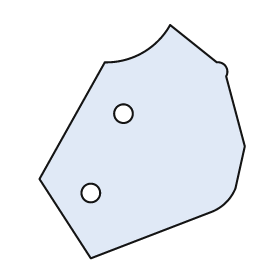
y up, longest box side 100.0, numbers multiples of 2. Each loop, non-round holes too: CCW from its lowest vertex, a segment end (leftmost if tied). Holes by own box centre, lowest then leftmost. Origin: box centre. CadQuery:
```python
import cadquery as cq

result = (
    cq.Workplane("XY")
    .moveTo(-22.0, -50.0)
    .lineTo(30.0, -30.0)
    .threePointArc((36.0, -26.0), (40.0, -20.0))
    .lineTo(44.0, -2.0)
    .lineTo(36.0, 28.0)
    .threePointArc((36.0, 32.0), (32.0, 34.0))
    .lineTo(12.0, 50.0)
    .threePointArc((0.0, 38.0), (-16.0, 34.0))
    .lineTo(-44.0, -16.0)
    .close()
    .moveTo(-22.0, -22.0)
    .circle(4.0)
    .moveTo(-8.0, 12.0)
    .circle(4.0)
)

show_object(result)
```